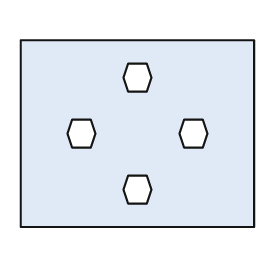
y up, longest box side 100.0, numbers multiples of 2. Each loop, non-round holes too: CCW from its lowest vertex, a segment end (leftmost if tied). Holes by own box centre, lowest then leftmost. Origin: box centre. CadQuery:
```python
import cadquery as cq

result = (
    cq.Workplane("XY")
    .moveTo(-50.0, -40.0)
    .lineTo(50.0, -40.0)
    .lineTo(50.0, 40.0)
    .lineTo(-50.0, 40.0)
    .close()
    .moveTo(-4.0, -30.0)
    .lineTo(4.0, -30.0)
    .lineTo(6.0, -24.0)
    .lineTo(4.0, -18.0)
    .lineTo(-4.0, -18.0)
    .lineTo(-6.0, -24.0)
    .close()
    .moveTo(-28.0, -6.0)
    .lineTo(-20.0, -6.0)
    .lineTo(-18.0, 0.0)
    .lineTo(-20.0, 6.0)
    .lineTo(-28.0, 6.0)
    .lineTo(-30.0, 0.0)
    .close()
    .moveTo(20.0, -6.0)
    .lineTo(28.0, -6.0)
    .lineTo(30.0, 0.0)
    .lineTo(28.0, 6.0)
    .lineTo(20.0, 6.0)
    .lineTo(18.0, 0.0)
    .close()
    .moveTo(-4.0, 18.0)
    .lineTo(4.0, 18.0)
    .lineTo(6.0, 24.0)
    .lineTo(4.0, 30.0)
    .lineTo(-4.0, 30.0)
    .lineTo(-6.0, 24.0)
    .close()
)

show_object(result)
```